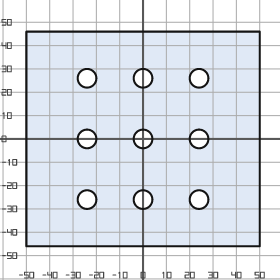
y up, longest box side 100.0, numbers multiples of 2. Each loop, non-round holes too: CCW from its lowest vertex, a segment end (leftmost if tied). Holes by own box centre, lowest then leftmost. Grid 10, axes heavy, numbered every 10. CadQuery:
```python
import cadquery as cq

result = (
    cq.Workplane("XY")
    .moveTo(-50.0, -46.0)
    .lineTo(50.0, -46.0)
    .lineTo(50.0, 46.0)
    .lineTo(-50.0, 46.0)
    .close()
    .moveTo(-24.0, -26.0)
    .circle(4.0)
    .moveTo(0.0, -26.0)
    .circle(4.0)
    .moveTo(24.0, -26.0)
    .circle(4.0)
    .moveTo(-24.0, 0.0)
    .circle(4.0)
    .moveTo(0.0, 0.0)
    .circle(4.0)
    .moveTo(24.0, 0.0)
    .circle(4.0)
    .moveTo(-24.0, 26.0)
    .circle(4.0)
    .moveTo(0.0, 26.0)
    .circle(4.0)
    .moveTo(24.0, 26.0)
    .circle(4.0)
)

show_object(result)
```